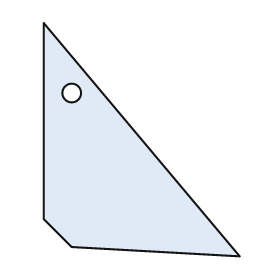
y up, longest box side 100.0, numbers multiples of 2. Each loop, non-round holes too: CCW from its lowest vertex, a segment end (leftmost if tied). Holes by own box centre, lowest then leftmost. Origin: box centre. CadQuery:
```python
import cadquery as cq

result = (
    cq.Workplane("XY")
    .moveTo(42.0, -50.0)
    .lineTo(-42.0, 50.0)
    .lineTo(-42.0, -34.0)
    .lineTo(-30.0, -46.0)
    .close()
    .moveTo(-30.0, 20.0)
    .circle(4.0)
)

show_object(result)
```